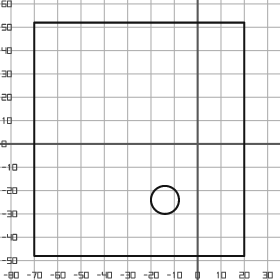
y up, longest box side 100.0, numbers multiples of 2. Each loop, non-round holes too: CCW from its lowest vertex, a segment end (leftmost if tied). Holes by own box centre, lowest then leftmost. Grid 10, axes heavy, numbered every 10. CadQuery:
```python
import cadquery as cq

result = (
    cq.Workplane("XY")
    .moveTo(-70.0, -48.0)
    .lineTo(20.0, -48.0)
    .lineTo(20.0, 52.0)
    .lineTo(-70.0, 52.0)
    .close()
    .moveTo(-14.0, -24.0)
    .circle(6.0)
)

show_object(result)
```